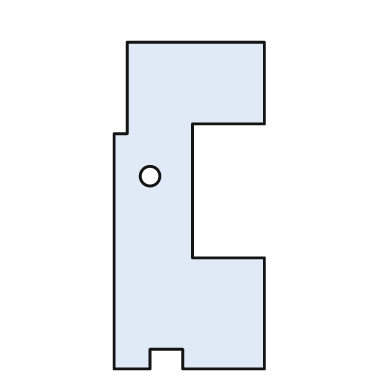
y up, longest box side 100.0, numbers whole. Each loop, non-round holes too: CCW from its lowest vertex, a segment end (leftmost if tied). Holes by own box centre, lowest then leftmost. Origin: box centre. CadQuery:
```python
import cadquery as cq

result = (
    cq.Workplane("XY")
    .moveTo(-23.0, -50.0)
    .lineTo(-12.0, -50.0)
    .lineTo(-12.0, -44.0)
    .lineTo(-2.0, -44.0)
    .lineTo(-2.0, -50.0)
    .lineTo(23.0, -50.0)
    .lineTo(23.0, -16.0)
    .lineTo(1.0, -16.0)
    .lineTo(1.0, 25.0)
    .lineTo(23.0, 25.0)
    .lineTo(23.0, 50.0)
    .lineTo(-19.0, 50.0)
    .lineTo(-19.0, 22.0)
    .lineTo(-23.0, 22.0)
    .close()
    .moveTo(-12.0, 9.0)
    .circle(3.0)
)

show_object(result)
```